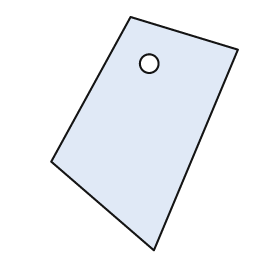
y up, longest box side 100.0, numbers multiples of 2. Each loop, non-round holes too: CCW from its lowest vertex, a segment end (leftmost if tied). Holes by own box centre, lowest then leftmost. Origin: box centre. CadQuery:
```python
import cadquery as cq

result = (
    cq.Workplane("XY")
    .moveTo(4.0, -50.0)
    .lineTo(40.0, 36.0)
    .lineTo(-6.0, 50.0)
    .lineTo(-40.0, -12.0)
    .close()
    .moveTo(2.0, 30.0)
    .circle(4.0)
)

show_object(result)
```